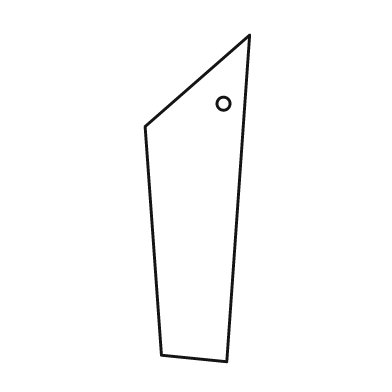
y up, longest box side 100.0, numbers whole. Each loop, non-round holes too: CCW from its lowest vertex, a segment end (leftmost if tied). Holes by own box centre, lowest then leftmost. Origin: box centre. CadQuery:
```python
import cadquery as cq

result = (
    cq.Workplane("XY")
    .moveTo(9.0, -50.0)
    .lineTo(16.0, 50.0)
    .lineTo(-16.0, 22.0)
    .lineTo(-11.0, -48.0)
    .close()
    .moveTo(8.0, 29.0)
    .circle(2.0)
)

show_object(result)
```